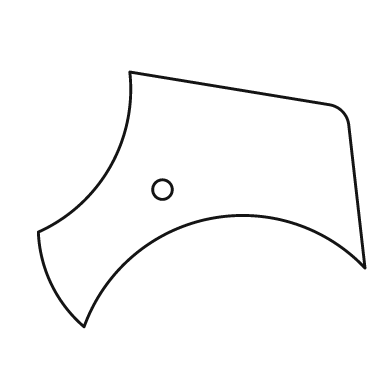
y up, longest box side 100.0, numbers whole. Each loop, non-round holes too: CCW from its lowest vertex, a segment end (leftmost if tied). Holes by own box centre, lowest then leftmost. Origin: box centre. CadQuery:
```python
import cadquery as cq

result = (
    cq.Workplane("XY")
    .moveTo(-36.0, -39.0)
    .threePointArc((2.0, -6.0), (50.0, -21.0))
    .lineTo(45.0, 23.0)
    .threePointArc((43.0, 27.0), (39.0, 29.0))
    .lineTo(-22.0, 39.0)
    .threePointArc((-28.0, 10.0), (-50.0, -10.0))
    .threePointArc((-46.0, -26.0), (-36.0, -39.0))
    .close()
    .moveTo(-12.0, 3.0)
    .circle(3.0)
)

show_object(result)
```